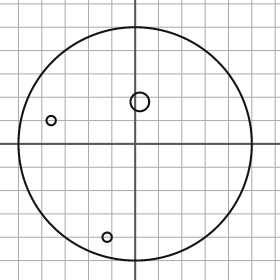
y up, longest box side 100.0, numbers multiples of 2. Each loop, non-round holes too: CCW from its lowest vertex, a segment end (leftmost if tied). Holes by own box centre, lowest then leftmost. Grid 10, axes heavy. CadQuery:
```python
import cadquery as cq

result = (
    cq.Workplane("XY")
    .moveTo(0.0, 0.0)
    .circle(50.0)
    .moveTo(-12.0, -40.0)
    .circle(2.0)
    .moveTo(-36.0, 10.0)
    .circle(2.0)
    .moveTo(2.0, 18.0)
    .circle(4.0)
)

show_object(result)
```